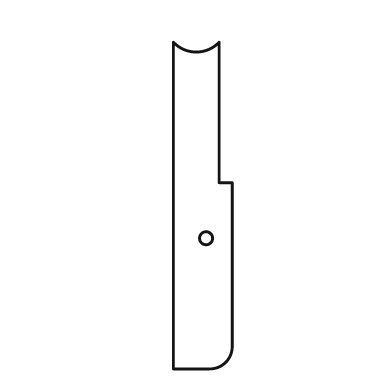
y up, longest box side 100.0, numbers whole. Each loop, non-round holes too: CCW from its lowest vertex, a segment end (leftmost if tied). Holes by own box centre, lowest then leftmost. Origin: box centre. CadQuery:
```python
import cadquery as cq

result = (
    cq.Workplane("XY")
    .moveTo(-9.0, -50.0)
    .lineTo(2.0, -50.0)
    .threePointArc((7.0, -48.0), (9.0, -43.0))
    .lineTo(9.0, 7.0)
    .lineTo(5.0, 7.0)
    .lineTo(5.0, 50.0)
    .threePointArc((-2.0, 47.0), (-9.0, 50.0))
    .close()
    .moveTo(1.0, -10.0)
    .circle(2.0)
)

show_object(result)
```